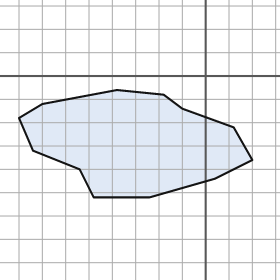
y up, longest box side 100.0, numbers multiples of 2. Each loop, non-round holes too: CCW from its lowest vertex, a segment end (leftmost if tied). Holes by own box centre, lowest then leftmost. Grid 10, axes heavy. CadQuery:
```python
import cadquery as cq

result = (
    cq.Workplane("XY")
    .moveTo(-48.0, -52.0)
    .lineTo(-24.0, -52.0)
    .lineTo(4.0, -44.0)
    .lineTo(20.0, -36.0)
    .lineTo(12.0, -22.0)
    .lineTo(-10.0, -14.0)
    .lineTo(-18.0, -8.0)
    .lineTo(-38.0, -6.0)
    .lineTo(-70.0, -12.0)
    .lineTo(-80.0, -18.0)
    .lineTo(-74.0, -32.0)
    .lineTo(-54.0, -40.0)
    .close()
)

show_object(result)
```